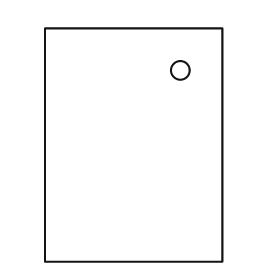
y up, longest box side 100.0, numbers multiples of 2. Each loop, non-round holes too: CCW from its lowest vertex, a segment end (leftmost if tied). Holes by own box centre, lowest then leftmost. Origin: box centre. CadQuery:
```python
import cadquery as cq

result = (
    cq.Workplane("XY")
    .moveTo(-38.0, -50.0)
    .lineTo(38.0, -50.0)
    .lineTo(38.0, 50.0)
    .lineTo(-38.0, 50.0)
    .close()
    .moveTo(20.0, 32.0)
    .circle(4.0)
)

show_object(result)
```